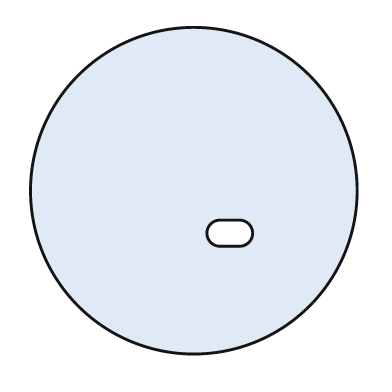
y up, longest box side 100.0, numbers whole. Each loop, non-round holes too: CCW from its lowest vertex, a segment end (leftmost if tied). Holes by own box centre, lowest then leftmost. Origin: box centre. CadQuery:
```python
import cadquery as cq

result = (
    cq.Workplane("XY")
    .moveTo(0.0, 0.0)
    .circle(50.0)
    .moveTo(8.0, -17.0)
    .lineTo(14.0, -17.0)
    .threePointArc((18.0, -13.0), (14.0, -9.0))
    .lineTo(8.0, -9.0)
    .threePointArc((4.0, -13.0), (8.0, -17.0))
    .close()
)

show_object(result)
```